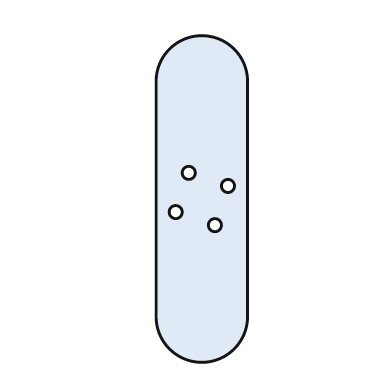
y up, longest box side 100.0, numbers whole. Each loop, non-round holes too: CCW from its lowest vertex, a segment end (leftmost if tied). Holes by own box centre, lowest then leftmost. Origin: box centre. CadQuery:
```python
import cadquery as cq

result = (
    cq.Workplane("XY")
    .moveTo(-14.0, -36.0)
    .threePointArc((0.0, -50.0), (14.0, -36.0))
    .lineTo(14.0, 36.0)
    .threePointArc((0.0, 50.0), (-14.0, 36.0))
    .close()
    .moveTo(4.0, -8.0)
    .circle(2.0)
    .moveTo(-8.0, -4.0)
    .circle(2.0)
    .moveTo(8.0, 4.0)
    .circle(2.0)
    .moveTo(-4.0, 8.0)
    .circle(2.0)
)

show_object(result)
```